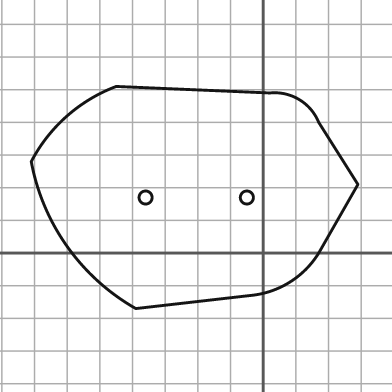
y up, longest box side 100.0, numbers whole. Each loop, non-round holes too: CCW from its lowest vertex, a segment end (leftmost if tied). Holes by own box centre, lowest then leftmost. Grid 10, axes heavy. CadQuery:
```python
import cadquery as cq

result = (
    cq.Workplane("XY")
    .moveTo(-39.0, -17.0)
    .lineTo(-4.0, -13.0)
    .threePointArc((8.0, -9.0), (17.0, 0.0))
    .lineTo(29.0, 21.0)
    .lineTo(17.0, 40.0)
    .threePointArc((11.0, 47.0), (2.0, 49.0))
    .lineTo(-45.0, 51.0)
    .threePointArc((-60.0, 42.0), (-71.0, 28.0))
    .threePointArc((-60.0, 2.0), (-39.0, -17.0))
    .close()
    .moveTo(-36.0, 17.0)
    .circle(2.0)
    .moveTo(-5.0, 17.0)
    .circle(2.0)
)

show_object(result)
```